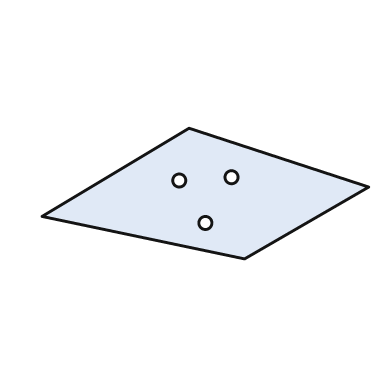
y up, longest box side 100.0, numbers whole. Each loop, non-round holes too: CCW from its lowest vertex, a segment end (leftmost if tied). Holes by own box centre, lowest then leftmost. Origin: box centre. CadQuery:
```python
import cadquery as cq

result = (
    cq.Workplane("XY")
    .moveTo(12.0, -20.0)
    .lineTo(50.0, 2.0)
    .lineTo(-5.0, 20.0)
    .lineTo(-50.0, -7.0)
    .close()
    .moveTo(0.0, -9.0)
    .circle(2.0)
    .moveTo(-8.0, 4.0)
    .circle(2.0)
    .moveTo(8.0, 5.0)
    .circle(2.0)
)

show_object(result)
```